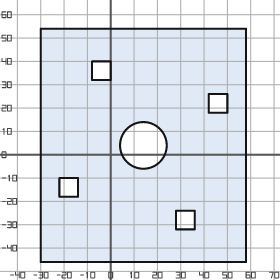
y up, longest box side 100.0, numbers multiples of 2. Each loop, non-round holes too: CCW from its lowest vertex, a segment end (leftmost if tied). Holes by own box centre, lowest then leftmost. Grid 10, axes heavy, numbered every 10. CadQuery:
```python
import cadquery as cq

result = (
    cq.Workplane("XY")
    .moveTo(-30.0, -46.0)
    .lineTo(58.0, -46.0)
    .lineTo(58.0, 54.0)
    .lineTo(-30.0, 54.0)
    .close()
    .moveTo(28.0, -32.0)
    .lineTo(36.0, -32.0)
    .lineTo(36.0, -24.0)
    .lineTo(28.0, -24.0)
    .close()
    .moveTo(-22.0, -18.0)
    .lineTo(-14.0, -18.0)
    .lineTo(-14.0, -10.0)
    .lineTo(-22.0, -10.0)
    .close()
    .moveTo(14.0, 4.0)
    .circle(10.0)
    .moveTo(42.0, 18.0)
    .lineTo(50.0, 18.0)
    .lineTo(50.0, 26.0)
    .lineTo(42.0, 26.0)
    .close()
    .moveTo(-8.0, 32.0)
    .lineTo(0.0, 32.0)
    .lineTo(0.0, 40.0)
    .lineTo(-8.0, 40.0)
    .close()
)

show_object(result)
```